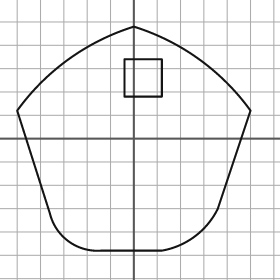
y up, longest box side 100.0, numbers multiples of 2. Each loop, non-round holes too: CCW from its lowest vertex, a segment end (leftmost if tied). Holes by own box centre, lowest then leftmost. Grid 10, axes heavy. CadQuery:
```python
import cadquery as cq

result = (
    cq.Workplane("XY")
    .moveTo(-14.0, -48.0)
    .lineTo(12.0, -48.0)
    .threePointArc((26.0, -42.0), (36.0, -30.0))
    .lineTo(50.0, 12.0)
    .threePointArc((28.0, 34.0), (0.0, 48.0))
    .threePointArc((-28.0, 34.0), (-50.0, 12.0))
    .lineTo(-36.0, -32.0)
    .threePointArc((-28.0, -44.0), (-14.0, -48.0))
    .close()
    .moveTo(-4.0, 18.0)
    .lineTo(12.0, 18.0)
    .lineTo(12.0, 34.0)
    .lineTo(-4.0, 34.0)
    .close()
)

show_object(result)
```